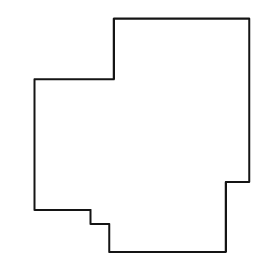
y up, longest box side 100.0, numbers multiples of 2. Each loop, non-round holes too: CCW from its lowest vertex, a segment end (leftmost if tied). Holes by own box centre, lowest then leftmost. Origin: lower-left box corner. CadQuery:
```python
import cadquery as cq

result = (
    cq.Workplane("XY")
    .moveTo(32.0, 0.0)
    .lineTo(82.0, 0.0)
    .lineTo(82.0, 30.0)
    .lineTo(92.0, 30.0)
    .lineTo(92.0, 100.0)
    .lineTo(34.0, 100.0)
    .lineTo(34.0, 74.0)
    .lineTo(0.0, 74.0)
    .lineTo(0.0, 18.0)
    .lineTo(24.0, 18.0)
    .lineTo(24.0, 12.0)
    .lineTo(32.0, 12.0)
    .close()
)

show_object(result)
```